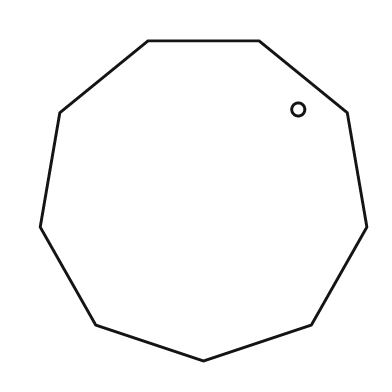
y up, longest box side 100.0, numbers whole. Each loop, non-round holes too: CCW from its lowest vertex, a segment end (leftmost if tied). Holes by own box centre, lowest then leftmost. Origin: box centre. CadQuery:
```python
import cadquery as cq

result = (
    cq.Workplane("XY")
    .moveTo(0.0, -49.0)
    .lineTo(33.0, -38.0)
    .lineTo(50.0, -8.0)
    .lineTo(44.0, 27.0)
    .lineTo(17.0, 49.0)
    .lineTo(-17.0, 49.0)
    .lineTo(-44.0, 27.0)
    .lineTo(-50.0, -8.0)
    .lineTo(-33.0, -38.0)
    .close()
    .moveTo(29.0, 28.0)
    .circle(2.0)
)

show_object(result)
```